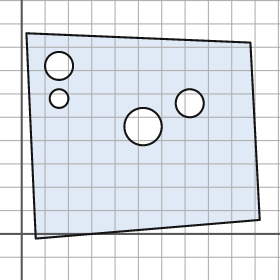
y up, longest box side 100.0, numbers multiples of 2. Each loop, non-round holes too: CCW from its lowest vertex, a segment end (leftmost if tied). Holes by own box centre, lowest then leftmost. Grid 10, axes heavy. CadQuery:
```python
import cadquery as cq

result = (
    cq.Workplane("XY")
    .moveTo(6.0, -2.0)
    .lineTo(102.0, 6.0)
    .lineTo(98.0, 82.0)
    .lineTo(2.0, 86.0)
    .close()
    .moveTo(52.0, 46.0)
    .circle(8.0)
    .moveTo(72.0, 56.0)
    .circle(6.0)
    .moveTo(16.0, 58.0)
    .circle(4.0)
    .moveTo(16.0, 72.0)
    .circle(6.0)
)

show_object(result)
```